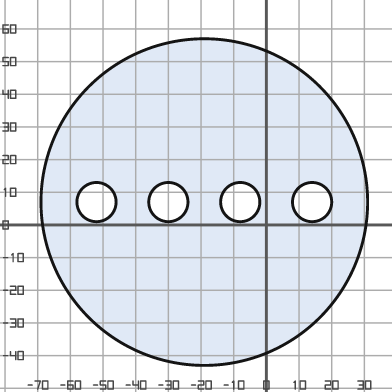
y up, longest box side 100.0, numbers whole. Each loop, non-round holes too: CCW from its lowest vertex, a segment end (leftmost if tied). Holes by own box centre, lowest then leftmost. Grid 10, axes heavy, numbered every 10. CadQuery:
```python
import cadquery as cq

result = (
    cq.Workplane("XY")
    .moveTo(-19.0, 7.0)
    .circle(50.0)
    .moveTo(-52.0, 7.0)
    .circle(6.0)
    .moveTo(-30.0, 7.0)
    .circle(6.0)
    .moveTo(-8.0, 7.0)
    .circle(6.0)
    .moveTo(14.0, 7.0)
    .circle(6.0)
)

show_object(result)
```